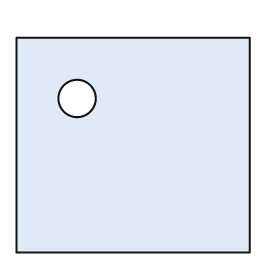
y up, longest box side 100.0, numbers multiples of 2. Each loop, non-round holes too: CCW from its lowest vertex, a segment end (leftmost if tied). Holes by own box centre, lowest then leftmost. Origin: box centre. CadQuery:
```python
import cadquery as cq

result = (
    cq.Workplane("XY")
    .moveTo(-50.0, -46.0)
    .lineTo(50.0, -46.0)
    .lineTo(50.0, 46.0)
    .lineTo(-50.0, 46.0)
    .close()
    .moveTo(-24.0, 20.0)
    .circle(8.0)
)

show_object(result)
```